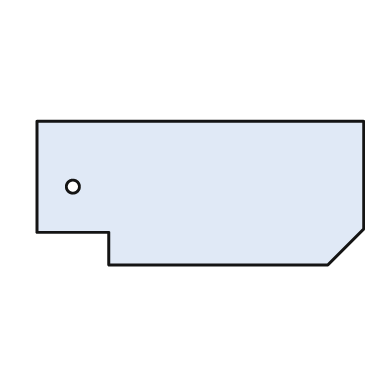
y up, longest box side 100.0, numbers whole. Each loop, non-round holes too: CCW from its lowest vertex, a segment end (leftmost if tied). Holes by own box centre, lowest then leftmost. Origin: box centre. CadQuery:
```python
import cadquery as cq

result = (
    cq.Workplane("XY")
    .moveTo(-28.0, -22.0)
    .lineTo(39.0, -22.0)
    .lineTo(50.0, -11.0)
    .lineTo(50.0, 22.0)
    .lineTo(-50.0, 22.0)
    .lineTo(-50.0, -12.0)
    .lineTo(-28.0, -12.0)
    .close()
    .moveTo(-39.0, 2.0)
    .circle(2.0)
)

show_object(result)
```